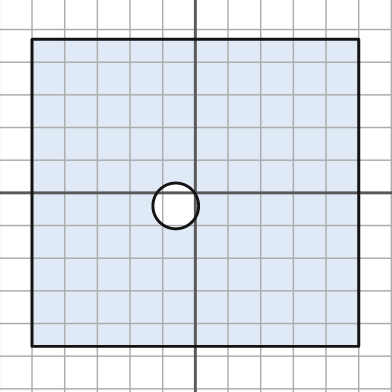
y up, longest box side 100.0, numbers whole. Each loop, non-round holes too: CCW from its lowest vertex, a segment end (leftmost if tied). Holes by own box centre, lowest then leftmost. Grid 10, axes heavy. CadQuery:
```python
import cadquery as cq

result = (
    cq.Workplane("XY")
    .moveTo(-50.0, -47.0)
    .lineTo(50.0, -47.0)
    .lineTo(50.0, 47.0)
    .lineTo(-50.0, 47.0)
    .close()
    .moveTo(-6.0, -4.0)
    .circle(7.0)
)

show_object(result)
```